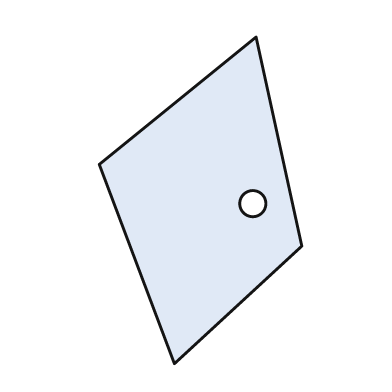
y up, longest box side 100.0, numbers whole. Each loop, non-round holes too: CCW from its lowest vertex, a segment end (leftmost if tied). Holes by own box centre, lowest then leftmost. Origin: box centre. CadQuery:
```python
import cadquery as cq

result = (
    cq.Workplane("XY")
    .moveTo(-8.0, -50.0)
    .lineTo(31.0, -14.0)
    .lineTo(17.0, 50.0)
    .lineTo(-31.0, 11.0)
    .close()
    .moveTo(16.0, -1.0)
    .circle(4.0)
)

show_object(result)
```